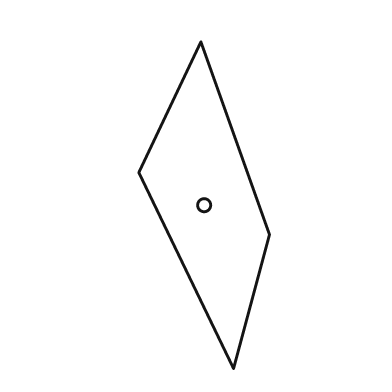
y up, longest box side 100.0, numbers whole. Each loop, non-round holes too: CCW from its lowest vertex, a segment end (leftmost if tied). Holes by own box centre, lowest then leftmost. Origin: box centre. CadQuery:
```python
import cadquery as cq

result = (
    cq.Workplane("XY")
    .moveTo(9.0, -50.0)
    .lineTo(20.0, -9.0)
    .lineTo(-1.0, 50.0)
    .lineTo(-20.0, 10.0)
    .close()
    .moveTo(0.0, 0.0)
    .circle(2.0)
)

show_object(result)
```